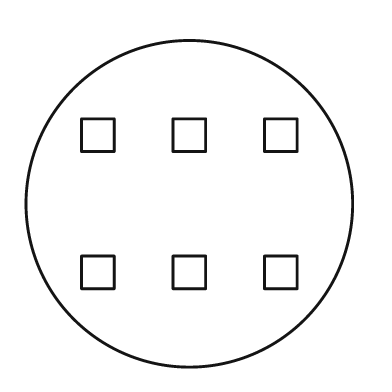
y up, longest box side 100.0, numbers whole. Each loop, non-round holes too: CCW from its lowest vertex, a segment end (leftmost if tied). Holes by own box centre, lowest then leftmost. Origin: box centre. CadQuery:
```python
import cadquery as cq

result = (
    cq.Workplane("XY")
    .moveTo(0.0, 0.0)
    .circle(50.0)
    .moveTo(-33.0, -26.0)
    .lineTo(-23.0, -26.0)
    .lineTo(-23.0, -16.0)
    .lineTo(-33.0, -16.0)
    .close()
    .moveTo(-5.0, -26.0)
    .lineTo(5.0, -26.0)
    .lineTo(5.0, -16.0)
    .lineTo(-5.0, -16.0)
    .close()
    .moveTo(23.0, -26.0)
    .lineTo(33.0, -26.0)
    .lineTo(33.0, -16.0)
    .lineTo(23.0, -16.0)
    .close()
    .moveTo(-33.0, 16.0)
    .lineTo(-23.0, 16.0)
    .lineTo(-23.0, 26.0)
    .lineTo(-33.0, 26.0)
    .close()
    .moveTo(-5.0, 16.0)
    .lineTo(5.0, 16.0)
    .lineTo(5.0, 26.0)
    .lineTo(-5.0, 26.0)
    .close()
    .moveTo(23.0, 16.0)
    .lineTo(33.0, 16.0)
    .lineTo(33.0, 26.0)
    .lineTo(23.0, 26.0)
    .close()
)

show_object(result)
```